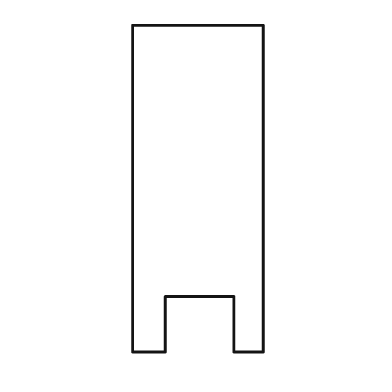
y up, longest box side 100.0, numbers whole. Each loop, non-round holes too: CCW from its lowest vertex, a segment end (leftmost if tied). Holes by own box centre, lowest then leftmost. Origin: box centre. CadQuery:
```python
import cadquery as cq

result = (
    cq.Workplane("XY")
    .moveTo(-20.0, -50.0)
    .lineTo(-10.0, -50.0)
    .lineTo(-10.0, -33.0)
    .lineTo(11.0, -33.0)
    .lineTo(11.0, -50.0)
    .lineTo(20.0, -50.0)
    .lineTo(20.0, 50.0)
    .lineTo(-20.0, 50.0)
    .close()
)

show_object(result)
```